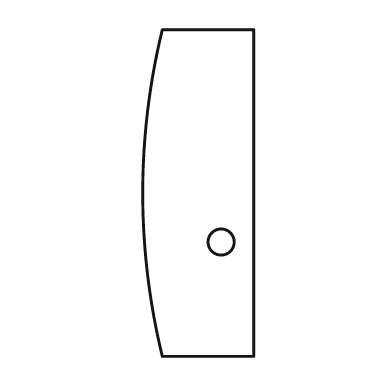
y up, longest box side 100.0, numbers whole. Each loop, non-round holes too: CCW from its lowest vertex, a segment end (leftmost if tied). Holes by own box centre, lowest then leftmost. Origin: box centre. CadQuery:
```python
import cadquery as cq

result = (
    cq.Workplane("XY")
    .moveTo(-11.0, -50.0)
    .lineTo(17.0, -50.0)
    .lineTo(17.0, 50.0)
    .lineTo(-11.0, 50.0)
    .threePointArc((-17.0, 0.0), (-11.0, -50.0))
    .close()
    .moveTo(7.0, -15.0)
    .circle(4.0)
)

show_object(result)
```